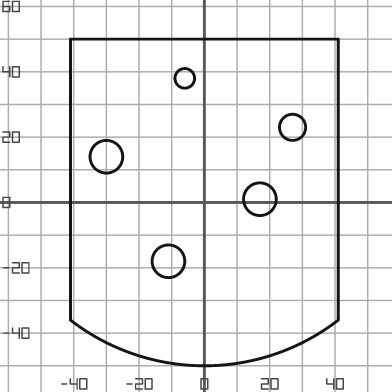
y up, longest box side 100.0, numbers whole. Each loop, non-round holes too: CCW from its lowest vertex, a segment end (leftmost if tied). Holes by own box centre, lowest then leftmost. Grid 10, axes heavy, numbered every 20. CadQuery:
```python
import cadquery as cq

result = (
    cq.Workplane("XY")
    .moveTo(-41.0, -36.0)
    .threePointArc((0.0, -50.0), (41.0, -36.0))
    .lineTo(41.0, 50.0)
    .lineTo(-41.0, 50.0)
    .close()
    .moveTo(-11.0, -18.0)
    .circle(5.0)
    .moveTo(17.0, 1.0)
    .circle(5.0)
    .moveTo(-30.0, 14.0)
    .circle(5.0)
    .moveTo(27.0, 23.0)
    .circle(4.0)
    .moveTo(-6.0, 38.0)
    .circle(3.0)
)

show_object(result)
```